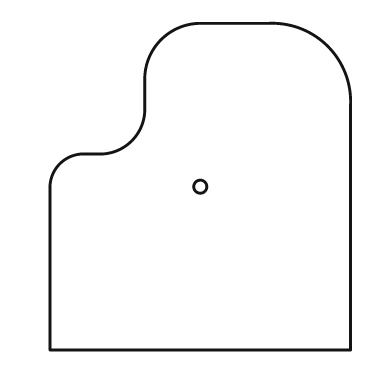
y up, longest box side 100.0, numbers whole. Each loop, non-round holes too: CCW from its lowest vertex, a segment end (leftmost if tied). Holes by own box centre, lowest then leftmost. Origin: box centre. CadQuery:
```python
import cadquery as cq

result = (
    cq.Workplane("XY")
    .moveTo(-46.0, -50.0)
    .lineTo(46.0, -50.0)
    .lineTo(46.0, 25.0)
    .threePointArc((39.0, 43.0), (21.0, 50.0))
    .lineTo(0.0, 50.0)
    .threePointArc((-12.0, 45.0), (-17.0, 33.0))
    .lineTo(-17.0, 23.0)
    .threePointArc((-21.0, 14.0), (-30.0, 10.0))
    .lineTo(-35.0, 10.0)
    .threePointArc((-43.0, 7.0), (-46.0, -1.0))
    .close()
    .moveTo(0.0, 0.0)
    .circle(2.0)
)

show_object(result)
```